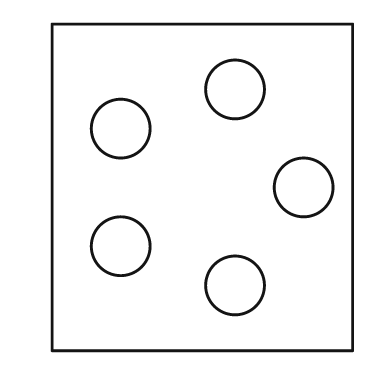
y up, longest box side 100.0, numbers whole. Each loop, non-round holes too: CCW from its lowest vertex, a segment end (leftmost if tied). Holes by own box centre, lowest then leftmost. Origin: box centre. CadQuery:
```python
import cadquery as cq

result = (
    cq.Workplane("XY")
    .moveTo(-46.0, -50.0)
    .lineTo(46.0, -50.0)
    .lineTo(46.0, 50.0)
    .lineTo(-46.0, 50.0)
    .close()
    .moveTo(10.0, -30.0)
    .circle(9.0)
    .moveTo(-25.0, -18.0)
    .circle(9.0)
    .moveTo(31.0, 0.0)
    .circle(9.0)
    .moveTo(-25.0, 18.0)
    .circle(9.0)
    .moveTo(10.0, 30.0)
    .circle(9.0)
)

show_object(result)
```